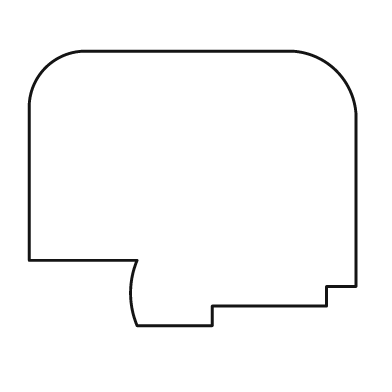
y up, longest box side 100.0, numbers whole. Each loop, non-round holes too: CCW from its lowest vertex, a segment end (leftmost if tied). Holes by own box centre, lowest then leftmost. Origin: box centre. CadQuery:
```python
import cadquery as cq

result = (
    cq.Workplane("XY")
    .moveTo(-17.0, -42.0)
    .lineTo(6.0, -42.0)
    .lineTo(6.0, -36.0)
    .lineTo(41.0, -36.0)
    .lineTo(41.0, -30.0)
    .lineTo(50.0, -30.0)
    .lineTo(50.0, 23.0)
    .threePointArc((44.0, 36.0), (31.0, 42.0))
    .lineTo(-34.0, 42.0)
    .threePointArc((-45.0, 37.0), (-50.0, 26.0))
    .lineTo(-50.0, -22.0)
    .lineTo(-17.0, -22.0)
    .threePointArc((-19.0, -32.0), (-17.0, -42.0))
    .close()
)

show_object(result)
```